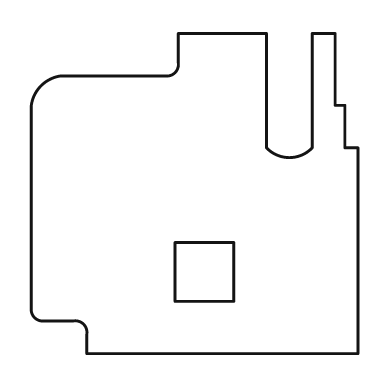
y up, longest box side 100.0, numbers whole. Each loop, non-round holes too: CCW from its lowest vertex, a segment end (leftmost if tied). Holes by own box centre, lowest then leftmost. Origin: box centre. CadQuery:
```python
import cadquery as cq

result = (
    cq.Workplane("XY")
    .moveTo(-33.0, -49.0)
    .lineTo(50.0, -49.0)
    .lineTo(50.0, 14.0)
    .lineTo(46.0, 14.0)
    .lineTo(46.0, 27.0)
    .lineTo(43.0, 27.0)
    .lineTo(43.0, 49.0)
    .lineTo(36.0, 49.0)
    .lineTo(36.0, 14.0)
    .threePointArc((29.0, 11.0), (22.0, 14.0))
    .lineTo(22.0, 49.0)
    .lineTo(-5.0, 49.0)
    .lineTo(-5.0, 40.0)
    .threePointArc((-6.0, 37.0), (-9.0, 36.0))
    .lineTo(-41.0, 36.0)
    .threePointArc((-47.0, 33.0), (-50.0, 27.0))
    .lineTo(-50.0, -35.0)
    .threePointArc((-49.0, -38.0), (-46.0, -39.0))
    .lineTo(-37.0, -39.0)
    .threePointArc((-34.0, -40.0), (-33.0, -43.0))
    .close()
    .moveTo(-6.0, -33.0)
    .lineTo(12.0, -33.0)
    .lineTo(12.0, -15.0)
    .lineTo(-6.0, -15.0)
    .close()
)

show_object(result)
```